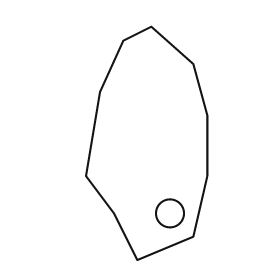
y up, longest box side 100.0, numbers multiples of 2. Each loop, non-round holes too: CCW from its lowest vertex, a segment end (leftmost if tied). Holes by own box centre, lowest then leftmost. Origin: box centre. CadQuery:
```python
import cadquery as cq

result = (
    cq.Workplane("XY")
    .moveTo(-4.0, -50.0)
    .lineTo(20.0, -40.0)
    .lineTo(26.0, -14.0)
    .lineTo(26.0, 12.0)
    .lineTo(20.0, 34.0)
    .lineTo(2.0, 50.0)
    .lineTo(-10.0, 44.0)
    .lineTo(-20.0, 22.0)
    .lineTo(-26.0, -14.0)
    .lineTo(-14.0, -30.0)
    .close()
    .moveTo(10.0, -30.0)
    .circle(6.0)
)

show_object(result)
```